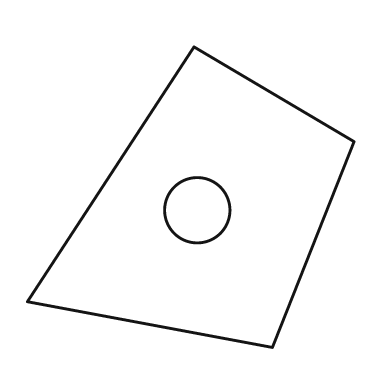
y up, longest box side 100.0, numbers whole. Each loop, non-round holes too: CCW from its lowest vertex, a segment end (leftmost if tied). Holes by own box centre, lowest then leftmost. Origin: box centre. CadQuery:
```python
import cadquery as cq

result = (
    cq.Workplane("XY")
    .moveTo(25.0, -46.0)
    .lineTo(50.0, 17.0)
    .lineTo(1.0, 46.0)
    .lineTo(-50.0, -32.0)
    .close()
    .moveTo(2.0, -4.0)
    .circle(10.0)
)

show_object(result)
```